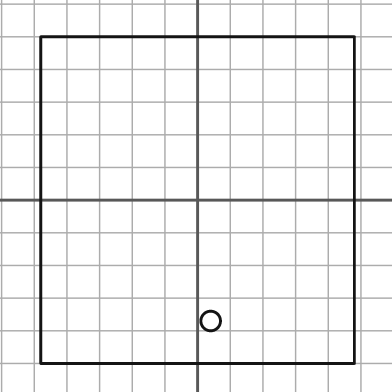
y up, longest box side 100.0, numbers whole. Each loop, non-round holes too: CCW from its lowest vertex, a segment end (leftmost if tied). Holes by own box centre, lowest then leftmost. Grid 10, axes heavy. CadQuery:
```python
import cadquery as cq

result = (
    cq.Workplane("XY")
    .moveTo(-48.0, -50.0)
    .lineTo(48.0, -50.0)
    .lineTo(48.0, 50.0)
    .lineTo(-48.0, 50.0)
    .close()
    .moveTo(4.0, -37.0)
    .circle(3.0)
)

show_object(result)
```